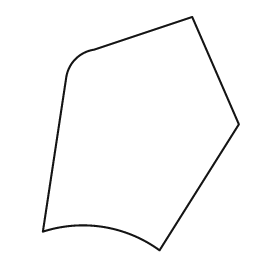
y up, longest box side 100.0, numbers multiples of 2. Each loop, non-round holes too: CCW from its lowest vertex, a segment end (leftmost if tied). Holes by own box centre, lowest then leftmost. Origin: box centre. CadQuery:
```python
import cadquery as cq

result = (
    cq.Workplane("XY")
    .moveTo(8.0, -50.0)
    .lineTo(42.0, 4.0)
    .lineTo(22.0, 50.0)
    .lineTo(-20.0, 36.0)
    .threePointArc((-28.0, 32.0), (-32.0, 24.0))
    .lineTo(-42.0, -42.0)
    .threePointArc((-16.0, -40.0), (8.0, -50.0))
    .close()
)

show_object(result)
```